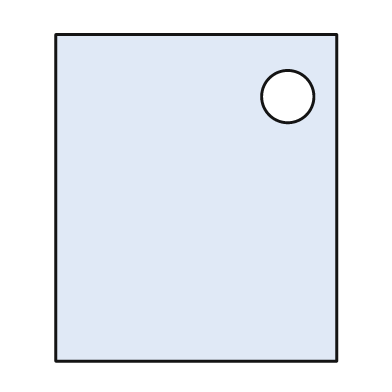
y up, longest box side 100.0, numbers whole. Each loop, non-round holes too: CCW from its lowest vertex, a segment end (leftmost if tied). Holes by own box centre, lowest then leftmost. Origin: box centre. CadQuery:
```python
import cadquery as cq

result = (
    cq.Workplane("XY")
    .moveTo(-43.0, -50.0)
    .lineTo(43.0, -50.0)
    .lineTo(43.0, 50.0)
    .lineTo(-43.0, 50.0)
    .close()
    .moveTo(28.0, 31.0)
    .circle(8.0)
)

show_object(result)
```